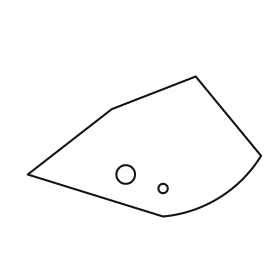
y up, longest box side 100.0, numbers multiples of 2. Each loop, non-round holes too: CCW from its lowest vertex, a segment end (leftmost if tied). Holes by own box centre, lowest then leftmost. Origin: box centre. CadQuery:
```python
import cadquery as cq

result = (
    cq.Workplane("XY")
    .moveTo(8.0, -30.0)
    .threePointArc((32.0, -22.0), (50.0, -4.0))
    .lineTo(22.0, 30.0)
    .lineTo(-14.0, 16.0)
    .lineTo(-50.0, -12.0)
    .close()
    .moveTo(8.0, -18.0)
    .circle(2.0)
    .moveTo(-8.0, -12.0)
    .circle(4.0)
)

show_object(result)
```